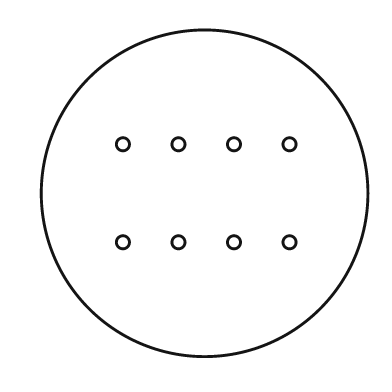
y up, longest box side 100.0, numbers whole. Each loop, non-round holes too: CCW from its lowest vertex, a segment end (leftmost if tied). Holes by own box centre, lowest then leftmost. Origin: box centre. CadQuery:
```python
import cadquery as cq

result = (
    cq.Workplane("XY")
    .moveTo(0.0, 0.0)
    .circle(50.0)
    .moveTo(-25.0, -15.0)
    .circle(2.0)
    .moveTo(-8.0, -15.0)
    .circle(2.0)
    .moveTo(9.0, -15.0)
    .circle(2.0)
    .moveTo(26.0, -15.0)
    .circle(2.0)
    .moveTo(-25.0, 15.0)
    .circle(2.0)
    .moveTo(-8.0, 15.0)
    .circle(2.0)
    .moveTo(9.0, 15.0)
    .circle(2.0)
    .moveTo(26.0, 15.0)
    .circle(2.0)
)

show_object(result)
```